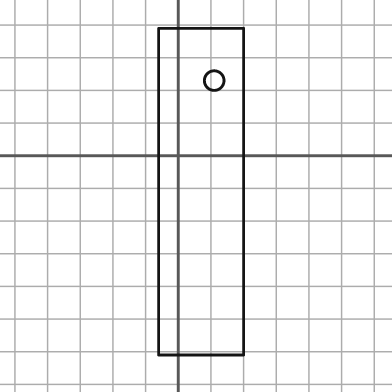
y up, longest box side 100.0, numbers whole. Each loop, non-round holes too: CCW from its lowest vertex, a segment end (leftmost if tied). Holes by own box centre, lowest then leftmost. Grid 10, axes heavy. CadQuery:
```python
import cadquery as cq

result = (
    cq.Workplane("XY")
    .moveTo(-6.0, -61.0)
    .lineTo(20.0, -61.0)
    .lineTo(20.0, 39.0)
    .lineTo(-6.0, 39.0)
    .close()
    .moveTo(11.0, 23.0)
    .circle(3.0)
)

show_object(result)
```